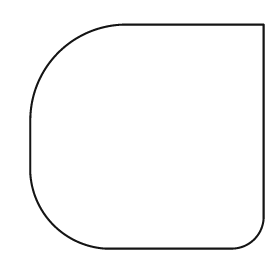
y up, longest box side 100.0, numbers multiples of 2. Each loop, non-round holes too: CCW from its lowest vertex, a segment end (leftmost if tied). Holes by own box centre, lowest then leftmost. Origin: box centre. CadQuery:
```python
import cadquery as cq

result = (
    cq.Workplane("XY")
    .moveTo(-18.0, -48.0)
    .lineTo(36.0, -48.0)
    .threePointArc((46.0, -44.0), (50.0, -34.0))
    .lineTo(50.0, 48.0)
    .lineTo(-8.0, 48.0)
    .threePointArc((-38.0, 36.0), (-50.0, 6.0))
    .lineTo(-50.0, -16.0)
    .threePointArc((-40.0, -38.0), (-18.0, -48.0))
    .close()
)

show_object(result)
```